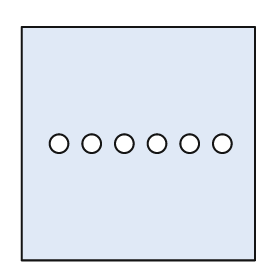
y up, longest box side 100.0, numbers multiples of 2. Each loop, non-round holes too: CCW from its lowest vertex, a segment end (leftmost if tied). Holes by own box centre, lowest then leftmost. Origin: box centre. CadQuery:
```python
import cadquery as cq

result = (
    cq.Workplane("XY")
    .moveTo(-50.0, -50.0)
    .lineTo(50.0, -50.0)
    .lineTo(50.0, 50.0)
    .lineTo(-50.0, 50.0)
    .close()
    .moveTo(-34.0, 0.0)
    .circle(4.0)
    .moveTo(-20.0, 0.0)
    .circle(4.0)
    .moveTo(-6.0, 0.0)
    .circle(4.0)
    .moveTo(8.0, 0.0)
    .circle(4.0)
    .moveTo(22.0, 0.0)
    .circle(4.0)
    .moveTo(36.0, 0.0)
    .circle(4.0)
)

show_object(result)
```